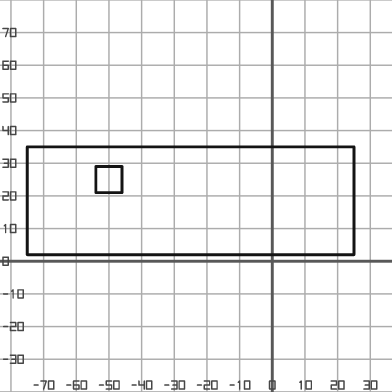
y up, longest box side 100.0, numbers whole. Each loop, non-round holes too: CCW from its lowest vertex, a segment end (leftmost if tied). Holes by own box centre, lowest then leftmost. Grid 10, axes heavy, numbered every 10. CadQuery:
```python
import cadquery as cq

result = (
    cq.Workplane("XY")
    .moveTo(-75.0, 2.0)
    .lineTo(25.0, 2.0)
    .lineTo(25.0, 35.0)
    .lineTo(-75.0, 35.0)
    .close()
    .moveTo(-54.0, 21.0)
    .lineTo(-46.0, 21.0)
    .lineTo(-46.0, 29.0)
    .lineTo(-54.0, 29.0)
    .close()
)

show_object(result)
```